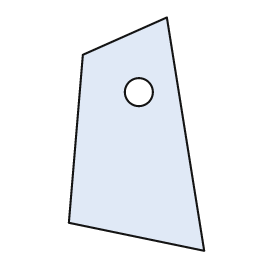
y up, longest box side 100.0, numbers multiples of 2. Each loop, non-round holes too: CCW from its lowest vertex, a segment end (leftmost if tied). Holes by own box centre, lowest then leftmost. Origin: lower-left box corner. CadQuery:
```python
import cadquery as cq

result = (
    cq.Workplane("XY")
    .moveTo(58.0, 0.0)
    .lineTo(42.0, 100.0)
    .lineTo(6.0, 84.0)
    .lineTo(0.0, 12.0)
    .close()
    .moveTo(30.0, 68.0)
    .circle(6.0)
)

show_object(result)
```